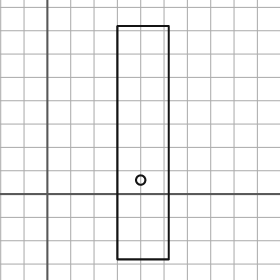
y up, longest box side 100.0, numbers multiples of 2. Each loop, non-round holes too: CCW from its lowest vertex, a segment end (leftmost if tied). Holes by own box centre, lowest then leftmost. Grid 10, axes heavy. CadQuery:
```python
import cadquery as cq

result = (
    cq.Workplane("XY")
    .moveTo(30.0, -28.0)
    .lineTo(52.0, -28.0)
    .lineTo(52.0, 72.0)
    .lineTo(30.0, 72.0)
    .close()
    .moveTo(40.0, 6.0)
    .circle(2.0)
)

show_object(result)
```